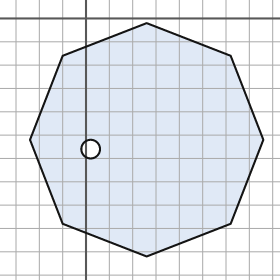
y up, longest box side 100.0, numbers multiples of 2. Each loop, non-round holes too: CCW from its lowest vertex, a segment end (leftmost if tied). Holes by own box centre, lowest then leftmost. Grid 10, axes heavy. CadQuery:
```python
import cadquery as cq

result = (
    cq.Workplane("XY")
    .moveTo(26.0, -102.0)
    .lineTo(62.0, -88.0)
    .lineTo(76.0, -52.0)
    .lineTo(62.0, -16.0)
    .lineTo(26.0, -2.0)
    .lineTo(-10.0, -16.0)
    .lineTo(-24.0, -52.0)
    .lineTo(-10.0, -88.0)
    .close()
    .moveTo(2.0, -56.0)
    .circle(4.0)
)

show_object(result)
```